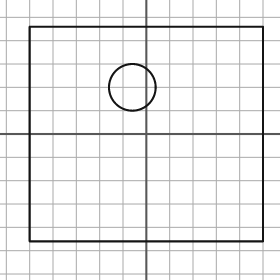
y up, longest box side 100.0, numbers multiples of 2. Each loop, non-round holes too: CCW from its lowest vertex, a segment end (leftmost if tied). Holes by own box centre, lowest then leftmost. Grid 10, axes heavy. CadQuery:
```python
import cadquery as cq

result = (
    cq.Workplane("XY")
    .moveTo(-50.0, -46.0)
    .lineTo(50.0, -46.0)
    .lineTo(50.0, 46.0)
    .lineTo(-50.0, 46.0)
    .close()
    .moveTo(-6.0, 20.0)
    .circle(10.0)
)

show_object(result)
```